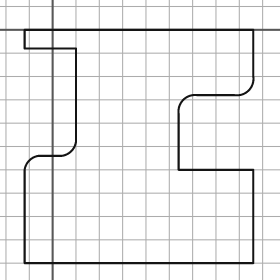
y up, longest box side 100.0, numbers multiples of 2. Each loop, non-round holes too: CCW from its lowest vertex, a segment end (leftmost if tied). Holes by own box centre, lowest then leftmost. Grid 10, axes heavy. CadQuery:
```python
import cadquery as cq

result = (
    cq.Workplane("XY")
    .moveTo(-12.0, -100.0)
    .lineTo(86.0, -100.0)
    .lineTo(86.0, -60.0)
    .lineTo(54.0, -60.0)
    .lineTo(54.0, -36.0)
    .threePointArc((56.0, -30.0), (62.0, -28.0))
    .lineTo(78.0, -28.0)
    .threePointArc((84.0, -26.0), (86.0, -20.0))
    .lineTo(86.0, 0.0)
    .lineTo(-12.0, 0.0)
    .lineTo(-12.0, -8.0)
    .lineTo(10.0, -8.0)
    .lineTo(10.0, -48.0)
    .threePointArc((8.0, -52.0), (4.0, -54.0))
    .lineTo(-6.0, -54.0)
    .threePointArc((-10.0, -56.0), (-12.0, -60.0))
    .close()
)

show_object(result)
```